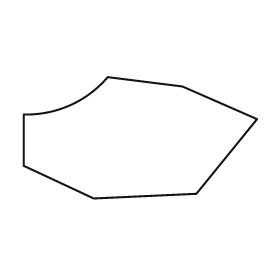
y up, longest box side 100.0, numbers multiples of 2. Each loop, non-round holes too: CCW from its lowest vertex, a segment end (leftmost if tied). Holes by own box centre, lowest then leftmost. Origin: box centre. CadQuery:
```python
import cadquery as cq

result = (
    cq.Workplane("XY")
    .moveTo(-20.0, -26.0)
    .lineTo(24.0, -24.0)
    .lineTo(50.0, 8.0)
    .lineTo(18.0, 22.0)
    .lineTo(-14.0, 26.0)
    .threePointArc((-30.0, 14.0), (-50.0, 10.0))
    .lineTo(-50.0, -12.0)
    .close()
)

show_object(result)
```